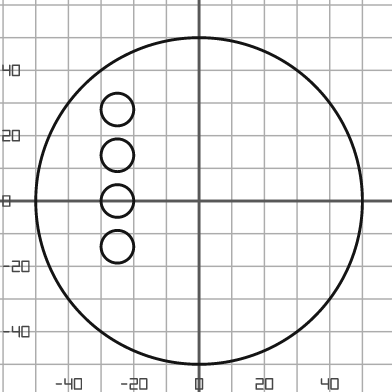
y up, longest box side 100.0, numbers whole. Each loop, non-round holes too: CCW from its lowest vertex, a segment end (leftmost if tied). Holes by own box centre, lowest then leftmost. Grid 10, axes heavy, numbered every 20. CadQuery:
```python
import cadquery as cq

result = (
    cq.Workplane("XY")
    .moveTo(0.0, 0.0)
    .circle(50.0)
    .moveTo(-25.0, -14.0)
    .circle(5.0)
    .moveTo(-25.0, 0.0)
    .circle(5.0)
    .moveTo(-25.0, 14.0)
    .circle(5.0)
    .moveTo(-25.0, 28.0)
    .circle(5.0)
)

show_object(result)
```